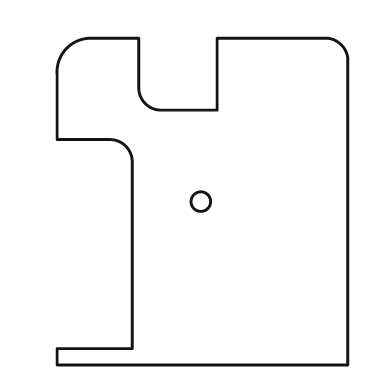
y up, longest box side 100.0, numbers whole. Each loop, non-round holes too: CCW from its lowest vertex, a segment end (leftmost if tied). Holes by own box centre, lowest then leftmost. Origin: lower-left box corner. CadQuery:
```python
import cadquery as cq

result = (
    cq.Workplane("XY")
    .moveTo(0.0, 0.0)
    .lineTo(89.0, 0.0)
    .lineTo(89.0, 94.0)
    .threePointArc((87.0, 98.0), (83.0, 100.0))
    .lineTo(49.0, 100.0)
    .lineTo(49.0, 78.0)
    .lineTo(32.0, 78.0)
    .threePointArc((27.0, 80.0), (25.0, 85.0))
    .lineTo(25.0, 100.0)
    .lineTo(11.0, 100.0)
    .threePointArc((3.0, 97.0), (0.0, 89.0))
    .lineTo(0.0, 69.0)
    .lineTo(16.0, 69.0)
    .threePointArc((21.0, 67.0), (23.0, 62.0))
    .lineTo(23.0, 5.0)
    .lineTo(0.0, 5.0)
    .close()
    .moveTo(44.0, 50.0)
    .circle(3.0)
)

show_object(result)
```